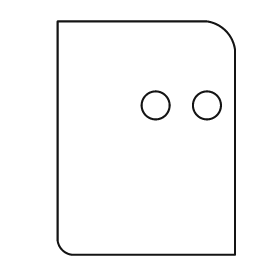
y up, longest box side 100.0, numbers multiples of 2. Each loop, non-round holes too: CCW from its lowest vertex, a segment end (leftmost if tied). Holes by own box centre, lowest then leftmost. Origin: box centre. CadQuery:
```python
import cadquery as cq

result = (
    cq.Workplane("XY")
    .moveTo(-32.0, -50.0)
    .lineTo(38.0, -50.0)
    .lineTo(38.0, 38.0)
    .threePointArc((34.0, 46.0), (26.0, 50.0))
    .lineTo(-38.0, 50.0)
    .lineTo(-38.0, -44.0)
    .threePointArc((-36.0, -48.0), (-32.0, -50.0))
    .close()
    .moveTo(4.0, 14.0)
    .circle(6.0)
    .moveTo(26.0, 14.0)
    .circle(6.0)
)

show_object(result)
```